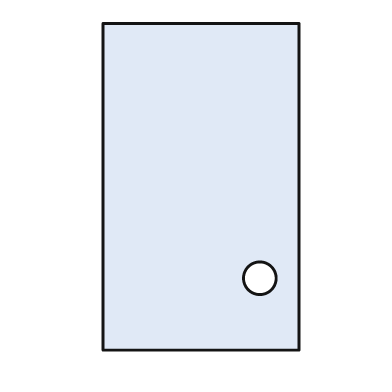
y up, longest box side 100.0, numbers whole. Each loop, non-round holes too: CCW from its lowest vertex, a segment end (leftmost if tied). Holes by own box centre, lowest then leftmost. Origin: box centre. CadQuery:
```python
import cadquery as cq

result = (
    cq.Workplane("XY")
    .moveTo(-30.0, -50.0)
    .lineTo(30.0, -50.0)
    .lineTo(30.0, 50.0)
    .lineTo(-30.0, 50.0)
    .close()
    .moveTo(18.0, -28.0)
    .circle(5.0)
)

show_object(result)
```